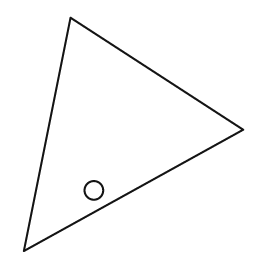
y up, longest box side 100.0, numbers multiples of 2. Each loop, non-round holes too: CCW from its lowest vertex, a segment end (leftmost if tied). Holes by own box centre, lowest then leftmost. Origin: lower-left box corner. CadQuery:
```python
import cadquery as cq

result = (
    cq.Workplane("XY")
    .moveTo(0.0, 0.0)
    .lineTo(94.0, 52.0)
    .lineTo(20.0, 100.0)
    .close()
    .moveTo(30.0, 26.0)
    .circle(4.0)
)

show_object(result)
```